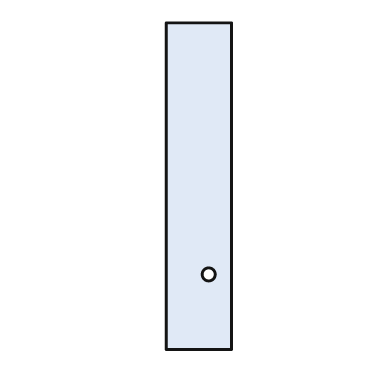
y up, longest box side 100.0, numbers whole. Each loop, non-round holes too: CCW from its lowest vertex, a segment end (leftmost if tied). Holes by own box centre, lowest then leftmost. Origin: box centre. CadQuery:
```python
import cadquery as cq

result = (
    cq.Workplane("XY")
    .moveTo(-10.0, -50.0)
    .lineTo(10.0, -50.0)
    .lineTo(10.0, 50.0)
    .lineTo(-10.0, 50.0)
    .close()
    .moveTo(3.0, -27.0)
    .circle(2.0)
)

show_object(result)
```